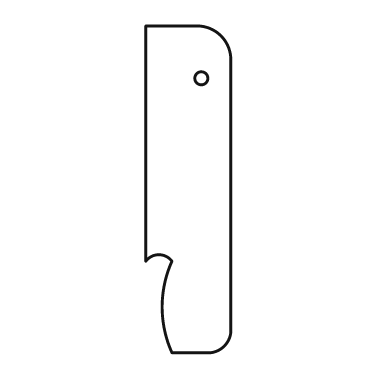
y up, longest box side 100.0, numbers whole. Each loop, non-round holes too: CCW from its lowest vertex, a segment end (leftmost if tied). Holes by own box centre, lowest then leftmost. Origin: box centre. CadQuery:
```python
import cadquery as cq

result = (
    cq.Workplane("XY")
    .moveTo(-5.0, -50.0)
    .lineTo(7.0, -50.0)
    .threePointArc((11.0, -48.0), (13.0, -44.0))
    .lineTo(13.0, 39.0)
    .threePointArc((10.0, 47.0), (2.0, 50.0))
    .lineTo(-13.0, 50.0)
    .lineTo(-13.0, -22.0)
    .threePointArc((-9.0, -20.0), (-5.0, -22.0))
    .threePointArc((-8.0, -36.0), (-5.0, -50.0))
    .close()
    .moveTo(4.0, 34.0)
    .circle(2.0)
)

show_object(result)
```